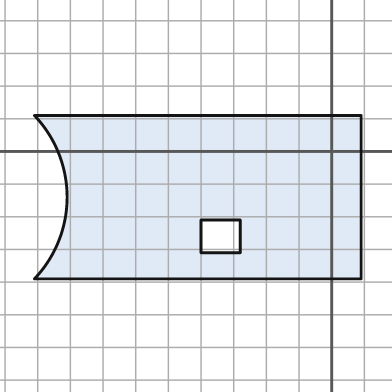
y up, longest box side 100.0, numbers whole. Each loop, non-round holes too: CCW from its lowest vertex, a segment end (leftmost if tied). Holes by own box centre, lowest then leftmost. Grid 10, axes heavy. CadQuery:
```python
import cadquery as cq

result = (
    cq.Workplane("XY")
    .moveTo(-91.0, -39.0)
    .lineTo(9.0, -39.0)
    .lineTo(9.0, 11.0)
    .lineTo(-91.0, 11.0)
    .threePointArc((-81.0, -14.0), (-91.0, -39.0))
    .close()
    .moveTo(-40.0, -31.0)
    .lineTo(-28.0, -31.0)
    .lineTo(-28.0, -21.0)
    .lineTo(-40.0, -21.0)
    .close()
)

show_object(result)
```